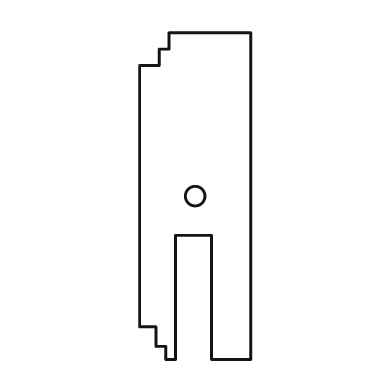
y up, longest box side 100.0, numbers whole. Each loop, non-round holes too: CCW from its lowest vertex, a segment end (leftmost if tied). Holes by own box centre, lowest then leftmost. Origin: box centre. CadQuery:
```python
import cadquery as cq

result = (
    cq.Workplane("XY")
    .moveTo(-9.0, -50.0)
    .lineTo(-6.0, -50.0)
    .lineTo(-6.0, -12.0)
    .lineTo(5.0, -12.0)
    .lineTo(5.0, -50.0)
    .lineTo(17.0, -50.0)
    .lineTo(17.0, 50.0)
    .lineTo(-8.0, 50.0)
    .lineTo(-8.0, 45.0)
    .lineTo(-11.0, 45.0)
    .lineTo(-11.0, 40.0)
    .lineTo(-17.0, 40.0)
    .lineTo(-17.0, -40.0)
    .lineTo(-12.0, -40.0)
    .lineTo(-12.0, -46.0)
    .lineTo(-9.0, -46.0)
    .close()
    .moveTo(0.0, 0.0)
    .circle(3.0)
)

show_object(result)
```